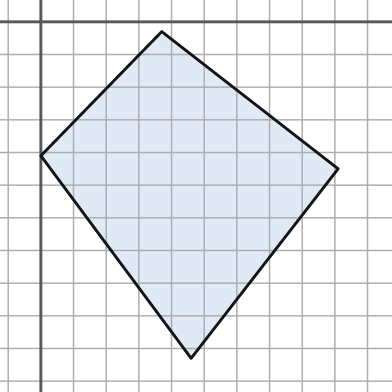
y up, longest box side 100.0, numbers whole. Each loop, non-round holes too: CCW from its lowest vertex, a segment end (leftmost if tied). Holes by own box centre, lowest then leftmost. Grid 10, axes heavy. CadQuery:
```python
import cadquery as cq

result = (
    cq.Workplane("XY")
    .moveTo(46.0, -103.0)
    .lineTo(91.0, -45.0)
    .lineTo(37.0, -3.0)
    .lineTo(0.0, -41.0)
    .close()
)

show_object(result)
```